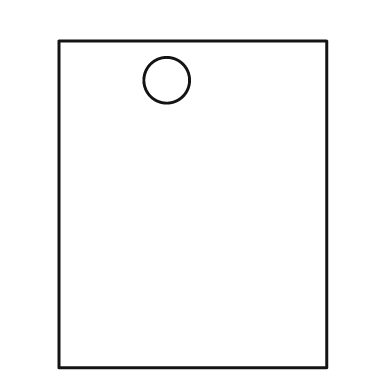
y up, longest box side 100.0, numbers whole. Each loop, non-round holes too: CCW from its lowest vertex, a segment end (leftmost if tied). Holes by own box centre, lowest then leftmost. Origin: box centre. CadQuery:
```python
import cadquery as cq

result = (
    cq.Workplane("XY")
    .moveTo(-41.0, -50.0)
    .lineTo(41.0, -50.0)
    .lineTo(41.0, 50.0)
    .lineTo(-41.0, 50.0)
    .close()
    .moveTo(-8.0, 38.0)
    .circle(7.0)
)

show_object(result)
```